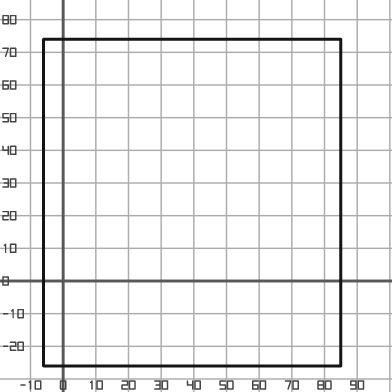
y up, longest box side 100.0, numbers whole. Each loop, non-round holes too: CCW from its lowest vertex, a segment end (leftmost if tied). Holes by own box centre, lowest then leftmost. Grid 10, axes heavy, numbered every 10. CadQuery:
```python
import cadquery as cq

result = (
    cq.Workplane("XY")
    .moveTo(-6.0, -26.0)
    .lineTo(85.0, -26.0)
    .lineTo(85.0, 74.0)
    .lineTo(-6.0, 74.0)
    .close()
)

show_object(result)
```